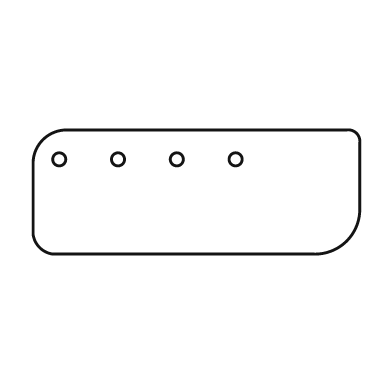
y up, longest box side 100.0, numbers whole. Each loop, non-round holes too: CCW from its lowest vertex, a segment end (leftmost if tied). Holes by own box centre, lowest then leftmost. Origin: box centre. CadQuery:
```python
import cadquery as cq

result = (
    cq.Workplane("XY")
    .moveTo(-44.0, -19.0)
    .lineTo(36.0, -19.0)
    .threePointArc((46.0, -15.0), (50.0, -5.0))
    .lineTo(50.0, 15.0)
    .threePointArc((49.0, 18.0), (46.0, 19.0))
    .lineTo(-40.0, 19.0)
    .threePointArc((-47.0, 16.0), (-50.0, 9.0))
    .lineTo(-50.0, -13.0)
    .threePointArc((-48.0, -17.0), (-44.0, -19.0))
    .close()
    .moveTo(-42.0, 10.0)
    .circle(2.0)
    .moveTo(-24.0, 10.0)
    .circle(2.0)
    .moveTo(-6.0, 10.0)
    .circle(2.0)
    .moveTo(12.0, 10.0)
    .circle(2.0)
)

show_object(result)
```